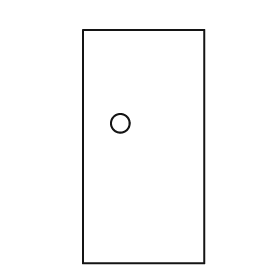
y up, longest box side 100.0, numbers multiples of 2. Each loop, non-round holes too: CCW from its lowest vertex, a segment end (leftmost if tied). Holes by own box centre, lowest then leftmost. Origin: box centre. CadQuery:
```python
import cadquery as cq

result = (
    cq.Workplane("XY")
    .moveTo(-26.0, -50.0)
    .lineTo(26.0, -50.0)
    .lineTo(26.0, 50.0)
    .lineTo(-26.0, 50.0)
    .close()
    .moveTo(-10.0, 10.0)
    .circle(4.0)
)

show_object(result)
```